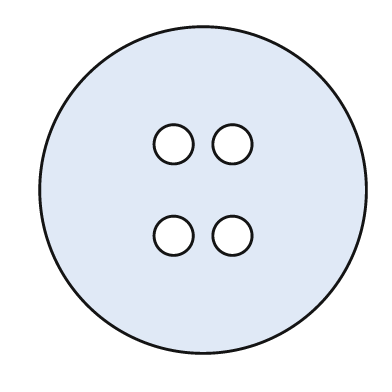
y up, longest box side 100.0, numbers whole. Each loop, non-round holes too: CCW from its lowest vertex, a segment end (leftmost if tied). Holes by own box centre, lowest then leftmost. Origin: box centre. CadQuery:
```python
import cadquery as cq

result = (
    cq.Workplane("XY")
    .moveTo(0.0, 0.0)
    .circle(50.0)
    .moveTo(-9.0, -14.0)
    .circle(6.0)
    .moveTo(9.0, -14.0)
    .circle(6.0)
    .moveTo(-9.0, 14.0)
    .circle(6.0)
    .moveTo(9.0, 14.0)
    .circle(6.0)
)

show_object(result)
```